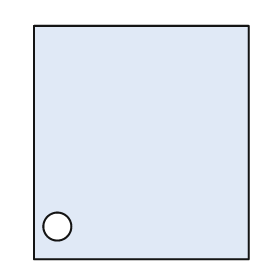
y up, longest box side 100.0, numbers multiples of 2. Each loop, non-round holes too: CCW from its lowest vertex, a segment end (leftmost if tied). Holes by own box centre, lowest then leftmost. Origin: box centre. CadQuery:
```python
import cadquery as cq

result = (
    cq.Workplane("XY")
    .moveTo(-46.0, -50.0)
    .lineTo(46.0, -50.0)
    .lineTo(46.0, 50.0)
    .lineTo(-46.0, 50.0)
    .close()
    .moveTo(-36.0, -36.0)
    .circle(6.0)
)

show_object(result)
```